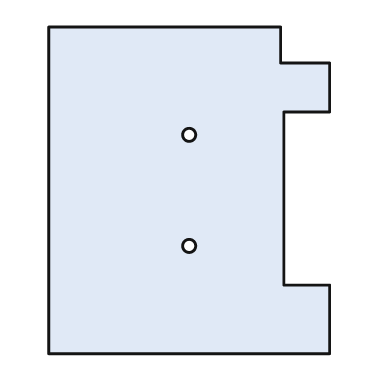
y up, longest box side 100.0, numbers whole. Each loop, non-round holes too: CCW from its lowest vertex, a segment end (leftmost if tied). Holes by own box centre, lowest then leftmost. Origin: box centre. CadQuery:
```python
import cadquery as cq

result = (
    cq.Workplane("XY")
    .moveTo(-43.0, -50.0)
    .lineTo(43.0, -50.0)
    .lineTo(43.0, -29.0)
    .lineTo(29.0, -29.0)
    .lineTo(29.0, 24.0)
    .lineTo(43.0, 24.0)
    .lineTo(43.0, 39.0)
    .lineTo(28.0, 39.0)
    .lineTo(28.0, 50.0)
    .lineTo(-43.0, 50.0)
    .close()
    .moveTo(0.0, -17.0)
    .circle(2.0)
    .moveTo(0.0, 17.0)
    .circle(2.0)
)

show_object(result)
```